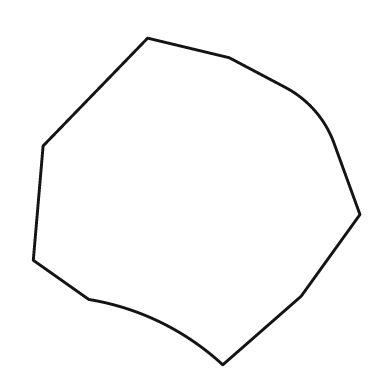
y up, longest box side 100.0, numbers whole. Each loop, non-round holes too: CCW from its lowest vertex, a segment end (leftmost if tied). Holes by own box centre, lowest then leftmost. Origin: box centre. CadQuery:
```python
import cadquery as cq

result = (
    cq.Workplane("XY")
    .moveTo(8.0, -50.0)
    .lineTo(32.0, -29.0)
    .lineTo(50.0, -4.0)
    .lineTo(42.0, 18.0)
    .threePointArc((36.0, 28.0), (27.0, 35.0))
    .lineTo(10.0, 44.0)
    .lineTo(-15.0, 50.0)
    .lineTo(-47.0, 17.0)
    .lineTo(-50.0, -18.0)
    .lineTo(-33.0, -30.0)
    .threePointArc((-11.0, -37.0), (8.0, -50.0))
    .close()
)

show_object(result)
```